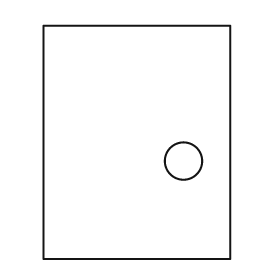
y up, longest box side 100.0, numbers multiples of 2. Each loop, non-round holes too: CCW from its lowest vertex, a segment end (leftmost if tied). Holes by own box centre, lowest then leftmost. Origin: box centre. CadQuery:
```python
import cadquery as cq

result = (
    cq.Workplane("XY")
    .moveTo(-40.0, -50.0)
    .lineTo(40.0, -50.0)
    .lineTo(40.0, 50.0)
    .lineTo(-40.0, 50.0)
    .close()
    .moveTo(20.0, -8.0)
    .circle(8.0)
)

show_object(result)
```